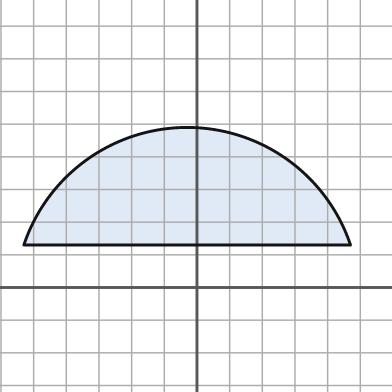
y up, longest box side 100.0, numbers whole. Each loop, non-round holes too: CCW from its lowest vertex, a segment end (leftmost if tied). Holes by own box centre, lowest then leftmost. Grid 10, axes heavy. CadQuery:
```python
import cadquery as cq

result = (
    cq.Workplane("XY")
    .moveTo(-53.0, 13.0)
    .lineTo(47.0, 13.0)
    .threePointArc((-3.0, 49.0), (-53.0, 13.0))
    .close()
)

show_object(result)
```